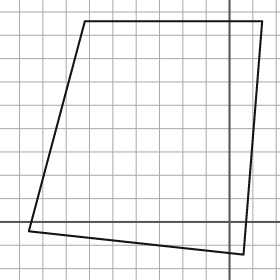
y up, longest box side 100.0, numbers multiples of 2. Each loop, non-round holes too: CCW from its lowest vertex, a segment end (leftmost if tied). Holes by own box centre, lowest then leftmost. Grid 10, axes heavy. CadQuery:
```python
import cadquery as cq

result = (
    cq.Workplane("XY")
    .moveTo(6.0, -14.0)
    .lineTo(14.0, 86.0)
    .lineTo(-62.0, 86.0)
    .lineTo(-86.0, -4.0)
    .close()
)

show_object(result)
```